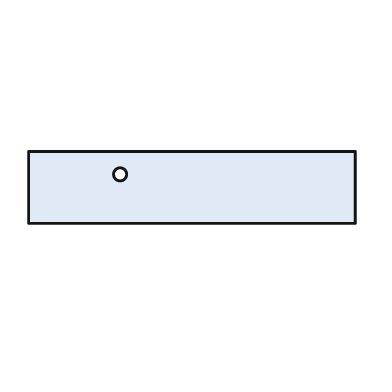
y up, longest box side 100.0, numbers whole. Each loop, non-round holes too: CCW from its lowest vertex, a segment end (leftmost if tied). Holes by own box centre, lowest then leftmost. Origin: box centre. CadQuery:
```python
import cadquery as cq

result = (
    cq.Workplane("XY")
    .moveTo(-50.0, -11.0)
    .lineTo(50.0, -11.0)
    .lineTo(50.0, 11.0)
    .lineTo(-50.0, 11.0)
    .close()
    .moveTo(-22.0, 4.0)
    .circle(2.0)
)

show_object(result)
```